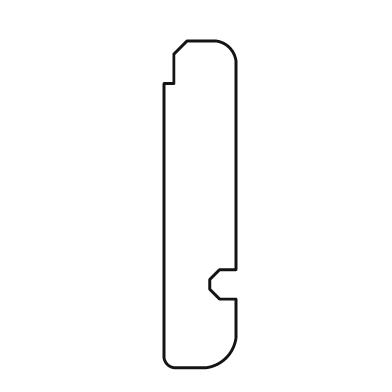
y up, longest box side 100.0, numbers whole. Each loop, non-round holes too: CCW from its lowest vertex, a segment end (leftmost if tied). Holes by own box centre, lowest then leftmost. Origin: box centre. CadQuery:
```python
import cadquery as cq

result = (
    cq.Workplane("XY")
    .moveTo(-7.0, -50.0)
    .lineTo(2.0, -50.0)
    .threePointArc((8.0, -47.0), (11.0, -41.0))
    .lineTo(11.0, -29.0)
    .lineTo(6.0, -29.0)
    .lineTo(3.0, -26.0)
    .lineTo(3.0, -23.0)
    .lineTo(6.0, -20.0)
    .lineTo(11.0, -20.0)
    .lineTo(11.0, 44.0)
    .threePointArc((9.0, 48.0), (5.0, 50.0))
    .lineTo(-4.0, 50.0)
    .lineTo(-8.0, 46.0)
    .lineTo(-8.0, 37.0)
    .lineTo(-11.0, 37.0)
    .lineTo(-11.0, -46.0)
    .threePointArc((-10.0, -49.0), (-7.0, -50.0))
    .close()
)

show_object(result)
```